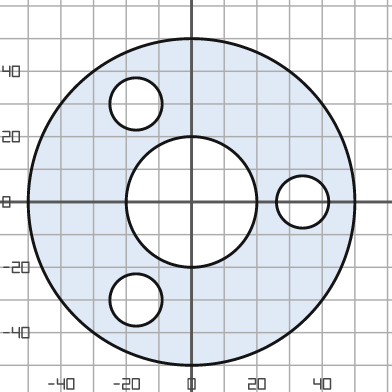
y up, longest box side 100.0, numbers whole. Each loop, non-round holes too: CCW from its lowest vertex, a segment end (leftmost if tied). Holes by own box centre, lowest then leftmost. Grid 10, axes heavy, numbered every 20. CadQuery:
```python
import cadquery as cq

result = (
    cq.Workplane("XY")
    .moveTo(0.0, 0.0)
    .circle(50.0)
    .moveTo(-17.0, -30.0)
    .circle(8.0)
    .moveTo(0.0, 0.0)
    .circle(20.0)
    .moveTo(34.0, 0.0)
    .circle(8.0)
    .moveTo(-17.0, 30.0)
    .circle(8.0)
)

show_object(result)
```